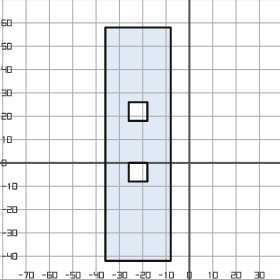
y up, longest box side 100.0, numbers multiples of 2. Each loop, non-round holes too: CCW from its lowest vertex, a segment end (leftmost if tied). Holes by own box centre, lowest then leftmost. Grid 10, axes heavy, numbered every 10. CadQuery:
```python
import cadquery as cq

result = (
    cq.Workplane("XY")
    .moveTo(-36.0, -42.0)
    .lineTo(-8.0, -42.0)
    .lineTo(-8.0, 58.0)
    .lineTo(-36.0, 58.0)
    .close()
    .moveTo(-26.0, -8.0)
    .lineTo(-18.0, -8.0)
    .lineTo(-18.0, 0.0)
    .lineTo(-26.0, 0.0)
    .close()
    .moveTo(-26.0, 18.0)
    .lineTo(-18.0, 18.0)
    .lineTo(-18.0, 26.0)
    .lineTo(-26.0, 26.0)
    .close()
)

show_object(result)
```